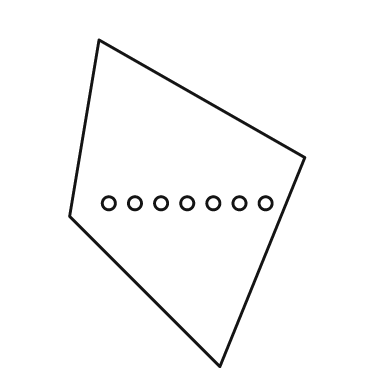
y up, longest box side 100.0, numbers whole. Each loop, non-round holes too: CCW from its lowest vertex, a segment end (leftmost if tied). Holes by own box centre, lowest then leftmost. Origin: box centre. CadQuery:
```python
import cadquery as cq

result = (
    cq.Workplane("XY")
    .moveTo(10.0, -50.0)
    .lineTo(36.0, 14.0)
    .lineTo(-27.0, 50.0)
    .lineTo(-36.0, -4.0)
    .close()
    .moveTo(-24.0, 0.0)
    .circle(2.0)
    .moveTo(-16.0, 0.0)
    .circle(2.0)
    .moveTo(-8.0, 0.0)
    .circle(2.0)
    .moveTo(0.0, 0.0)
    .circle(2.0)
    .moveTo(8.0, 0.0)
    .circle(2.0)
    .moveTo(16.0, 0.0)
    .circle(2.0)
    .moveTo(24.0, 0.0)
    .circle(2.0)
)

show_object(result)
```